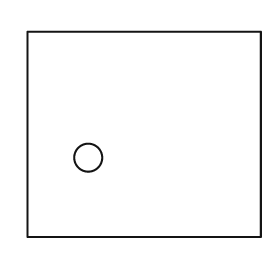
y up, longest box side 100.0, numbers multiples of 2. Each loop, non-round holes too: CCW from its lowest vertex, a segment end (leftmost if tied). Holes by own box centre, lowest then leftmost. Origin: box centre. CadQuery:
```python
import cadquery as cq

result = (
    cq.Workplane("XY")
    .moveTo(-50.0, -44.0)
    .lineTo(50.0, -44.0)
    .lineTo(50.0, 44.0)
    .lineTo(-50.0, 44.0)
    .close()
    .moveTo(-24.0, -10.0)
    .circle(6.0)
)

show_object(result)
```